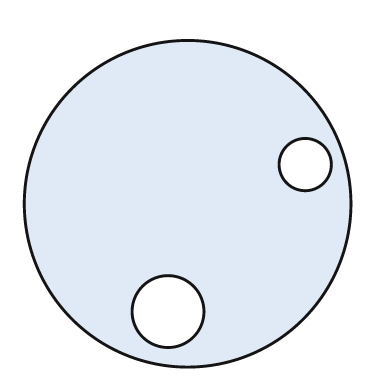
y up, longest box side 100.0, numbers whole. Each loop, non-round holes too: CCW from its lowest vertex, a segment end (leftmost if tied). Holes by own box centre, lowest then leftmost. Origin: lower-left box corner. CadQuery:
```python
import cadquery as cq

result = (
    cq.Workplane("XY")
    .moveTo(50.0, 50.0)
    .circle(50.0)
    .moveTo(44.0, 17.0)
    .circle(11.0)
    .moveTo(86.0, 62.0)
    .circle(8.0)
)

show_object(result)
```